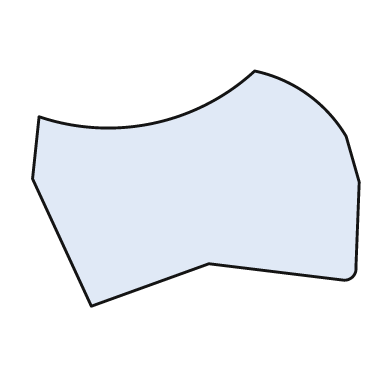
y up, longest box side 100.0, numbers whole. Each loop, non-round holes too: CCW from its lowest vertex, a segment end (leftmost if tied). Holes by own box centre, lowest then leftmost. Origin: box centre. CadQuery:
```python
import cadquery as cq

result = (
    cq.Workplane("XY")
    .moveTo(-32.0, -36.0)
    .lineTo(4.0, -23.0)
    .lineTo(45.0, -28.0)
    .threePointArc((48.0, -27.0), (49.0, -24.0))
    .lineTo(50.0, 2.0)
    .lineTo(46.0, 16.0)
    .threePointArc((34.0, 29.0), (18.0, 36.0))
    .threePointArc((-13.0, 20.0), (-48.0, 22.0))
    .lineTo(-50.0, 3.0)
    .close()
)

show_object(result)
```